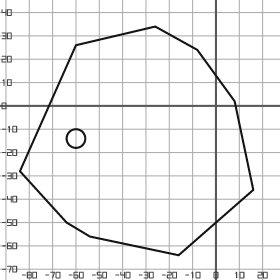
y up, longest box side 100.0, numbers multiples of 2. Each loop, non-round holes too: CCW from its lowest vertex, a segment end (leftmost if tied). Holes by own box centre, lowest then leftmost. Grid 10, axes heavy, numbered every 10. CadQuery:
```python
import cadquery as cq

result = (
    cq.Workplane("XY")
    .moveTo(-16.0, -64.0)
    .lineTo(16.0, -36.0)
    .lineTo(8.0, 2.0)
    .lineTo(-8.0, 24.0)
    .lineTo(-26.0, 34.0)
    .lineTo(-60.0, 26.0)
    .lineTo(-84.0, -28.0)
    .lineTo(-64.0, -50.0)
    .lineTo(-54.0, -56.0)
    .close()
    .moveTo(-60.0, -14.0)
    .circle(4.0)
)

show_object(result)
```